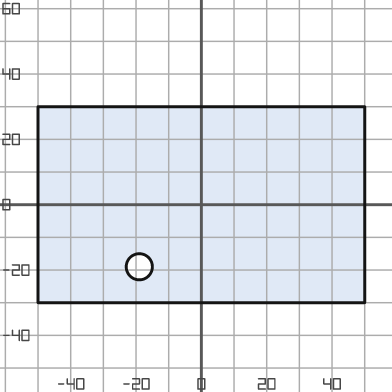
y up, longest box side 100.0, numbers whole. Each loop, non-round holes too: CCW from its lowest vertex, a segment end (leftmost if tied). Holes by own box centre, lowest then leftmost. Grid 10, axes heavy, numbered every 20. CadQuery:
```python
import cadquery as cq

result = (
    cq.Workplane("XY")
    .moveTo(-50.0, -30.0)
    .lineTo(50.0, -30.0)
    .lineTo(50.0, 30.0)
    .lineTo(-50.0, 30.0)
    .close()
    .moveTo(-19.0, -19.0)
    .circle(4.0)
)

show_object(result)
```